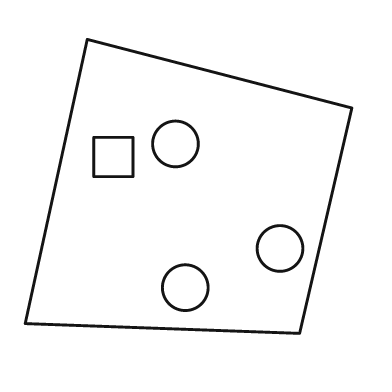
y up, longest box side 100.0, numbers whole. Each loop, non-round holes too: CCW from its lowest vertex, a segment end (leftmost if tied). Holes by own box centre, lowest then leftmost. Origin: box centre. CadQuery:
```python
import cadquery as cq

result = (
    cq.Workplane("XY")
    .moveTo(34.0, -45.0)
    .lineTo(50.0, 24.0)
    .lineTo(-31.0, 45.0)
    .lineTo(-50.0, -42.0)
    .close()
    .moveTo(-1.0, -31.0)
    .circle(7.0)
    .moveTo(28.0, -19.0)
    .circle(7.0)
    .moveTo(-29.0, 3.0)
    .lineTo(-17.0, 3.0)
    .lineTo(-17.0, 15.0)
    .lineTo(-29.0, 15.0)
    .close()
    .moveTo(-4.0, 13.0)
    .circle(7.0)
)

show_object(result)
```